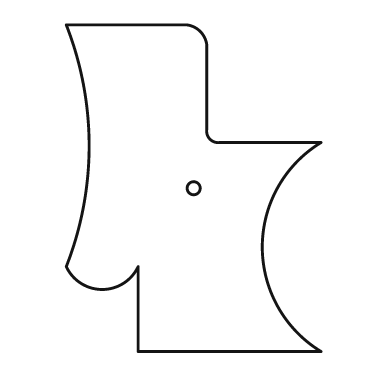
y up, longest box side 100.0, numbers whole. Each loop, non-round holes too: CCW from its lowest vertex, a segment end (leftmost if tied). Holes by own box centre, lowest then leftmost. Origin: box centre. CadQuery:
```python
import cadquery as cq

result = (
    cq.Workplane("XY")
    .moveTo(-17.0, -50.0)
    .lineTo(39.0, -50.0)
    .threePointArc((21.0, -18.0), (39.0, 14.0))
    .lineTo(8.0, 14.0)
    .threePointArc((5.0, 15.0), (4.0, 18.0))
    .lineTo(4.0, 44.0)
    .threePointArc((2.0, 48.0), (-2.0, 50.0))
    .lineTo(-39.0, 50.0)
    .threePointArc((-32.0, 13.0), (-39.0, -24.0))
    .threePointArc((-28.0, -31.0), (-17.0, -24.0))
    .close()
    .moveTo(0.0, 0.0)
    .circle(2.0)
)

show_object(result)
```